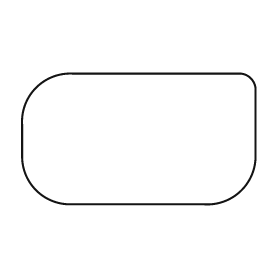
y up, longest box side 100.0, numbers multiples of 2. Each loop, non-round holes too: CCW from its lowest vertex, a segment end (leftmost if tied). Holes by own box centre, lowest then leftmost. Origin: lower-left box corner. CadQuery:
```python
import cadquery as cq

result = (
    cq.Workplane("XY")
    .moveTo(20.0, 0.0)
    .lineTo(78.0, 0.0)
    .threePointArc((94.0, 6.0), (100.0, 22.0))
    .lineTo(100.0, 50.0)
    .threePointArc((98.0, 54.0), (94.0, 56.0))
    .lineTo(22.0, 56.0)
    .threePointArc((6.0, 50.0), (0.0, 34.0))
    .lineTo(0.0, 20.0)
    .threePointArc((6.0, 6.0), (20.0, 0.0))
    .close()
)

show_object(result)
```